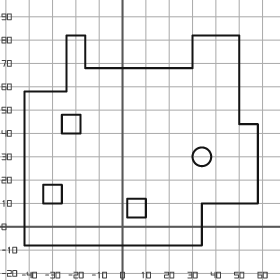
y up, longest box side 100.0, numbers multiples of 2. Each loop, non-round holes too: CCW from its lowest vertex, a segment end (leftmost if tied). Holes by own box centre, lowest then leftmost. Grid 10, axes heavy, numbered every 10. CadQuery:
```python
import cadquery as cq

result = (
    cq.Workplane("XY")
    .moveTo(-42.0, -8.0)
    .lineTo(34.0, -8.0)
    .lineTo(34.0, 10.0)
    .lineTo(58.0, 10.0)
    .lineTo(58.0, 44.0)
    .lineTo(50.0, 44.0)
    .lineTo(50.0, 82.0)
    .lineTo(30.0, 82.0)
    .lineTo(30.0, 68.0)
    .lineTo(-16.0, 68.0)
    .lineTo(-16.0, 82.0)
    .lineTo(-24.0, 82.0)
    .lineTo(-24.0, 58.0)
    .lineTo(-42.0, 58.0)
    .close()
    .moveTo(2.0, 4.0)
    .lineTo(10.0, 4.0)
    .lineTo(10.0, 12.0)
    .lineTo(2.0, 12.0)
    .close()
    .moveTo(-34.0, 10.0)
    .lineTo(-26.0, 10.0)
    .lineTo(-26.0, 18.0)
    .lineTo(-34.0, 18.0)
    .close()
    .moveTo(34.0, 30.0)
    .circle(4.0)
    .moveTo(-26.0, 40.0)
    .lineTo(-18.0, 40.0)
    .lineTo(-18.0, 48.0)
    .lineTo(-26.0, 48.0)
    .close()
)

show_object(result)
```